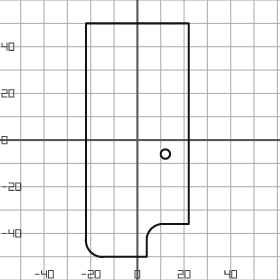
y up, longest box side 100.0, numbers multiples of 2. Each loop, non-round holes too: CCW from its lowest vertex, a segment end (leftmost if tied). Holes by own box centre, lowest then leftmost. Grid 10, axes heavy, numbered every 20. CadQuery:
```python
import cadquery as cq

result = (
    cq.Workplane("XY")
    .moveTo(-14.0, -50.0)
    .lineTo(4.0, -50.0)
    .lineTo(4.0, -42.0)
    .threePointArc((6.0, -38.0), (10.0, -36.0))
    .lineTo(22.0, -36.0)
    .lineTo(22.0, 50.0)
    .lineTo(-22.0, 50.0)
    .lineTo(-22.0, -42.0)
    .threePointArc((-20.0, -48.0), (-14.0, -50.0))
    .close()
    .moveTo(12.0, -6.0)
    .circle(2.0)
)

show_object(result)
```